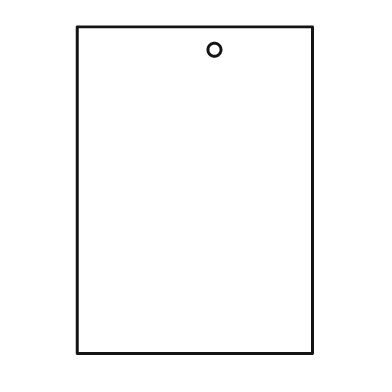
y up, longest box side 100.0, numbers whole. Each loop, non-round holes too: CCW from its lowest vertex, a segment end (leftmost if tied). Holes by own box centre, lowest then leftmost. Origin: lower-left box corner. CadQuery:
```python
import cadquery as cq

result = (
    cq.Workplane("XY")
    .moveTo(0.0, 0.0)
    .lineTo(72.0, 0.0)
    .lineTo(72.0, 100.0)
    .lineTo(0.0, 100.0)
    .close()
    .moveTo(42.0, 93.0)
    .circle(2.0)
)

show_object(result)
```